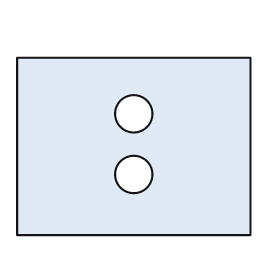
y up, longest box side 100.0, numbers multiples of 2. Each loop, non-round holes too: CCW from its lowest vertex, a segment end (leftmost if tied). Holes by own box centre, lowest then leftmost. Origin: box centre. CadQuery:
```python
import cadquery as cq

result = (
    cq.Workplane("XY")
    .moveTo(-50.0, -38.0)
    .lineTo(50.0, -38.0)
    .lineTo(50.0, 38.0)
    .lineTo(-50.0, 38.0)
    .close()
    .moveTo(0.0, -12.0)
    .circle(8.0)
    .moveTo(0.0, 14.0)
    .circle(8.0)
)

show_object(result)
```